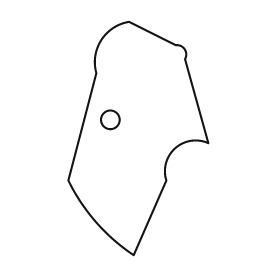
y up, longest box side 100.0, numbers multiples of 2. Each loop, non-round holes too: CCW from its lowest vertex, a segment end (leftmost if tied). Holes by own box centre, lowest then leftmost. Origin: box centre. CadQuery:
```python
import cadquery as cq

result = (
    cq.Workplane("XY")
    .moveTo(-2.0, -50.0)
    .lineTo(12.0, -18.0)
    .threePointArc((16.0, -4.0), (30.0, -2.0))
    .lineTo(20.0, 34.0)
    .threePointArc((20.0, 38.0), (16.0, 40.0))
    .lineTo(-4.0, 50.0)
    .threePointArc((-16.0, 42.0), (-18.0, 28.0))
    .lineTo(-30.0, -18.0)
    .threePointArc((-18.0, -36.0), (-2.0, -50.0))
    .close()
    .moveTo(-12.0, 8.0)
    .circle(4.0)
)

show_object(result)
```